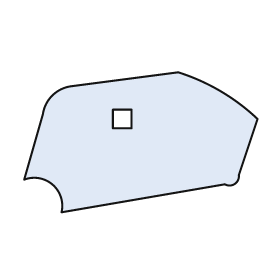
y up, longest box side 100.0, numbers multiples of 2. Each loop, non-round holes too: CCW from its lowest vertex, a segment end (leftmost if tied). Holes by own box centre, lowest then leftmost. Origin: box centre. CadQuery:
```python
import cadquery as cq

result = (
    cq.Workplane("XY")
    .moveTo(-34.0, -30.0)
    .lineTo(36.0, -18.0)
    .threePointArc((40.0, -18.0), (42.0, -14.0))
    .lineTo(50.0, 10.0)
    .threePointArc((34.0, 22.0), (16.0, 30.0))
    .lineTo(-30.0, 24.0)
    .threePointArc((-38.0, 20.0), (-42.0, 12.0))
    .lineTo(-50.0, -16.0)
    .threePointArc((-38.0, -18.0), (-34.0, -30.0))
    .close()
    .moveTo(-12.0, 6.0)
    .lineTo(-4.0, 6.0)
    .lineTo(-4.0, 14.0)
    .lineTo(-12.0, 14.0)
    .close()
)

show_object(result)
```